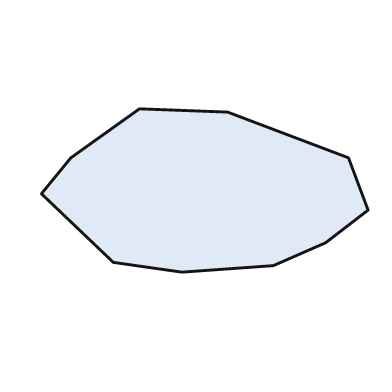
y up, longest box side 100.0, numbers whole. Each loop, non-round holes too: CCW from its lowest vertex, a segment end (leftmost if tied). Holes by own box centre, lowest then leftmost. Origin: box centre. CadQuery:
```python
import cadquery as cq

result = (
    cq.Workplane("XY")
    .moveTo(-7.0, -25.0)
    .lineTo(21.0, -23.0)
    .lineTo(37.0, -16.0)
    .lineTo(50.0, -6.0)
    .lineTo(44.0, 10.0)
    .lineTo(7.0, 24.0)
    .lineTo(-20.0, 25.0)
    .lineTo(-41.0, 10.0)
    .lineTo(-50.0, -1.0)
    .lineTo(-28.0, -22.0)
    .close()
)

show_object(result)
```